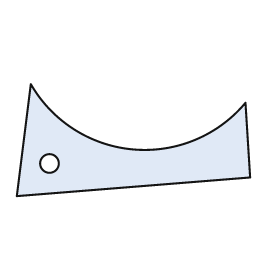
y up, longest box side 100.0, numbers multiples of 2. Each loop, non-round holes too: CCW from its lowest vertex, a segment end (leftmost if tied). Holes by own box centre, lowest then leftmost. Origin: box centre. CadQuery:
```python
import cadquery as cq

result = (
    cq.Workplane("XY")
    .moveTo(-50.0, -24.0)
    .lineTo(50.0, -16.0)
    .lineTo(48.0, 16.0)
    .threePointArc((0.0, -4.0), (-44.0, 24.0))
    .close()
    .moveTo(-36.0, -10.0)
    .circle(4.0)
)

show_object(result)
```